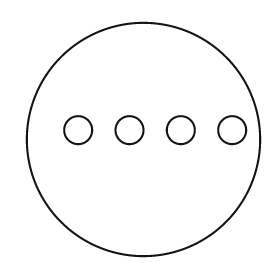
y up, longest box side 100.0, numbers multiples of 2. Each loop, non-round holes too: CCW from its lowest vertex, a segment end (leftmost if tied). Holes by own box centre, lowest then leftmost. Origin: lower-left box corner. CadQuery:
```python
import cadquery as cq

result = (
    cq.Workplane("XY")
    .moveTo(50.0, 50.0)
    .circle(50.0)
    .moveTo(22.0, 54.0)
    .circle(6.0)
    .moveTo(44.0, 54.0)
    .circle(6.0)
    .moveTo(66.0, 54.0)
    .circle(6.0)
    .moveTo(88.0, 54.0)
    .circle(6.0)
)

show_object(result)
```